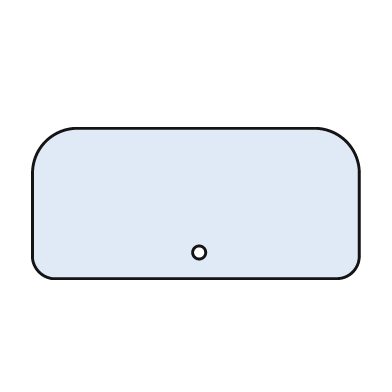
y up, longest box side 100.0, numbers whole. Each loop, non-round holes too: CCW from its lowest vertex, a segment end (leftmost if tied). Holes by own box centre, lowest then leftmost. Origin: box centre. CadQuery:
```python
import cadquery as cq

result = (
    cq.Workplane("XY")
    .moveTo(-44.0, -23.0)
    .lineTo(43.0, -23.0)
    .threePointArc((48.0, -21.0), (50.0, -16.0))
    .lineTo(50.0, 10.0)
    .threePointArc((46.0, 19.0), (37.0, 23.0))
    .lineTo(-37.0, 23.0)
    .threePointArc((-46.0, 19.0), (-50.0, 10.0))
    .lineTo(-50.0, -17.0)
    .threePointArc((-48.0, -21.0), (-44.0, -23.0))
    .close()
    .moveTo(1.0, -15.0)
    .circle(2.0)
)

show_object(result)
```